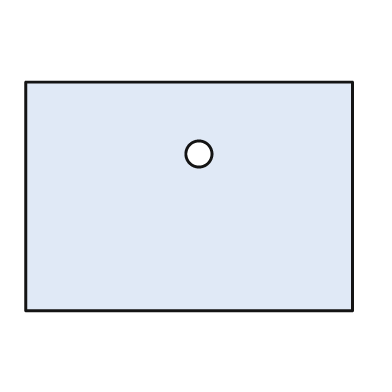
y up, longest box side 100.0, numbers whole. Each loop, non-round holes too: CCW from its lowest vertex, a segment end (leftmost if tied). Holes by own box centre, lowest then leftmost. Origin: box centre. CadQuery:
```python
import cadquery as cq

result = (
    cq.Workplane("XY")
    .moveTo(-50.0, -35.0)
    .lineTo(50.0, -35.0)
    .lineTo(50.0, 35.0)
    .lineTo(-50.0, 35.0)
    .close()
    .moveTo(3.0, 13.0)
    .circle(4.0)
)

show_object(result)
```